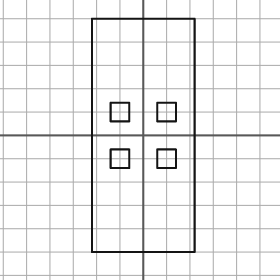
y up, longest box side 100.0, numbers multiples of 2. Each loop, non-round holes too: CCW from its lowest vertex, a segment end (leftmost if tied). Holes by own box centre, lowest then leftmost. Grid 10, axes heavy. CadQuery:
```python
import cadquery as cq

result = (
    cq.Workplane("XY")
    .moveTo(-22.0, -50.0)
    .lineTo(22.0, -50.0)
    .lineTo(22.0, 50.0)
    .lineTo(-22.0, 50.0)
    .close()
    .moveTo(-14.0, -14.0)
    .lineTo(-6.0, -14.0)
    .lineTo(-6.0, -6.0)
    .lineTo(-14.0, -6.0)
    .close()
    .moveTo(6.0, -14.0)
    .lineTo(14.0, -14.0)
    .lineTo(14.0, -6.0)
    .lineTo(6.0, -6.0)
    .close()
    .moveTo(-14.0, 6.0)
    .lineTo(-6.0, 6.0)
    .lineTo(-6.0, 14.0)
    .lineTo(-14.0, 14.0)
    .close()
    .moveTo(6.0, 6.0)
    .lineTo(14.0, 6.0)
    .lineTo(14.0, 14.0)
    .lineTo(6.0, 14.0)
    .close()
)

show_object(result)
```